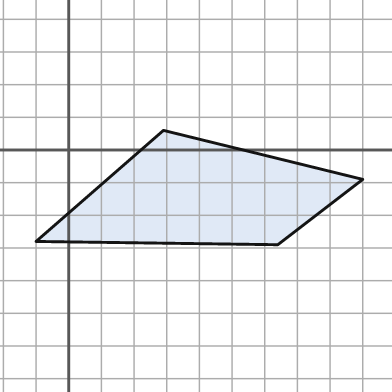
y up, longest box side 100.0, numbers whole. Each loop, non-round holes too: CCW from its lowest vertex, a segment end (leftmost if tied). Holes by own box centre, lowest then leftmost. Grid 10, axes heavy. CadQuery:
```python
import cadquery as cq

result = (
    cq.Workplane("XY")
    .moveTo(64.0, -29.0)
    .lineTo(90.0, -9.0)
    .lineTo(29.0, 6.0)
    .lineTo(-10.0, -28.0)
    .close()
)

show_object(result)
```